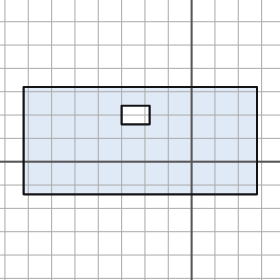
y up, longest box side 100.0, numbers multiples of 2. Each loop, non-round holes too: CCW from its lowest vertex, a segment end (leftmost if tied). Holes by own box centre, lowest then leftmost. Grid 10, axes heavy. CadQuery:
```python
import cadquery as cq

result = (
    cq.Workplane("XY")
    .moveTo(-72.0, -14.0)
    .lineTo(28.0, -14.0)
    .lineTo(28.0, 32.0)
    .lineTo(-72.0, 32.0)
    .close()
    .moveTo(-30.0, 16.0)
    .lineTo(-18.0, 16.0)
    .lineTo(-18.0, 24.0)
    .lineTo(-30.0, 24.0)
    .close()
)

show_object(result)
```